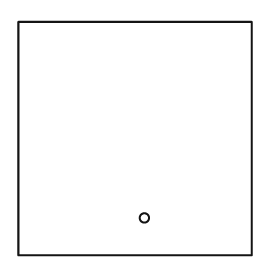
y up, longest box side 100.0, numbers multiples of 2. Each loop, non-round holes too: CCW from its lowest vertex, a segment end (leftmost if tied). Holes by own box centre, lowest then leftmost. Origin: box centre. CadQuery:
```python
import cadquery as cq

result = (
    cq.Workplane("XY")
    .moveTo(-50.0, -50.0)
    .lineTo(50.0, -50.0)
    .lineTo(50.0, 50.0)
    .lineTo(-50.0, 50.0)
    .close()
    .moveTo(4.0, -34.0)
    .circle(2.0)
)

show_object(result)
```